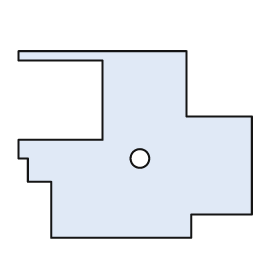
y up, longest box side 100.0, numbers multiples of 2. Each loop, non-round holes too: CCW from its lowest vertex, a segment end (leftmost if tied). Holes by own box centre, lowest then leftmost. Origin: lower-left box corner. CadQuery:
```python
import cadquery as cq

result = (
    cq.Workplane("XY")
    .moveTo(14.0, 0.0)
    .lineTo(74.0, 0.0)
    .lineTo(74.0, 10.0)
    .lineTo(100.0, 10.0)
    .lineTo(100.0, 52.0)
    .lineTo(72.0, 52.0)
    .lineTo(72.0, 80.0)
    .lineTo(0.0, 80.0)
    .lineTo(0.0, 76.0)
    .lineTo(36.0, 76.0)
    .lineTo(36.0, 42.0)
    .lineTo(0.0, 42.0)
    .lineTo(0.0, 34.0)
    .lineTo(4.0, 34.0)
    .lineTo(4.0, 24.0)
    .lineTo(14.0, 24.0)
    .close()
    .moveTo(52.0, 34.0)
    .circle(4.0)
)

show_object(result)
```